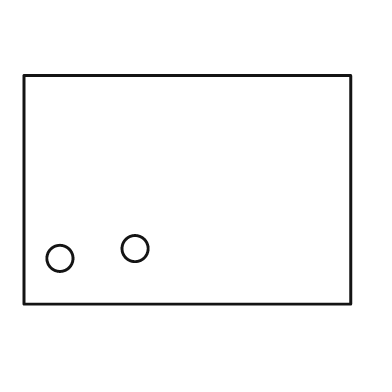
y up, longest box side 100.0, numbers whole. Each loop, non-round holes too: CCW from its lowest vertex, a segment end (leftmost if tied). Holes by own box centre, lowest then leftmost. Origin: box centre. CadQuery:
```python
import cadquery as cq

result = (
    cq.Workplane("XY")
    .moveTo(-50.0, -35.0)
    .lineTo(50.0, -35.0)
    .lineTo(50.0, 35.0)
    .lineTo(-50.0, 35.0)
    .close()
    .moveTo(-39.0, -21.0)
    .circle(4.0)
    .moveTo(-16.0, -18.0)
    .circle(4.0)
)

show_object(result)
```